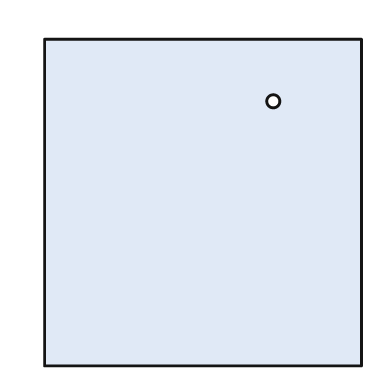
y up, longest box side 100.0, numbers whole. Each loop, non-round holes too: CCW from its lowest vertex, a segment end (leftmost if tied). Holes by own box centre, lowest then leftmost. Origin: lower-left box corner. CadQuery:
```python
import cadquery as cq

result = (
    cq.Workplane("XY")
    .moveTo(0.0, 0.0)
    .lineTo(97.0, 0.0)
    .lineTo(97.0, 100.0)
    .lineTo(0.0, 100.0)
    .close()
    .moveTo(70.0, 81.0)
    .circle(2.0)
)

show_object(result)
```